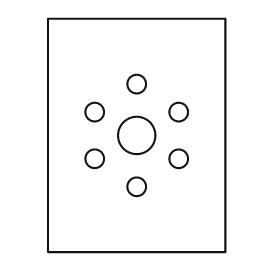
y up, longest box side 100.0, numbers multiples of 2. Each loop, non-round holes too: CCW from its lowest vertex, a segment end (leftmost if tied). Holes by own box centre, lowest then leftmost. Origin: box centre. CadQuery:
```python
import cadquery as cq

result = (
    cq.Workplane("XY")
    .moveTo(-38.0, -50.0)
    .lineTo(38.0, -50.0)
    .lineTo(38.0, 50.0)
    .lineTo(-38.0, 50.0)
    .close()
    .moveTo(0.0, -22.0)
    .circle(4.0)
    .moveTo(-18.0, -10.0)
    .circle(4.0)
    .moveTo(18.0, -10.0)
    .circle(4.0)
    .moveTo(0.0, 0.0)
    .circle(8.0)
    .moveTo(-18.0, 10.0)
    .circle(4.0)
    .moveTo(18.0, 10.0)
    .circle(4.0)
    .moveTo(0.0, 22.0)
    .circle(4.0)
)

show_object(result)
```